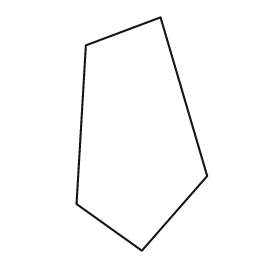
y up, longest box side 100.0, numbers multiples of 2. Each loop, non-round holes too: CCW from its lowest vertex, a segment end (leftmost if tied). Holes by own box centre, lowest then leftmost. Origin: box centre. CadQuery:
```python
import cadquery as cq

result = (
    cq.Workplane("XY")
    .moveTo(0.0, -50.0)
    .lineTo(28.0, -18.0)
    .lineTo(8.0, 50.0)
    .lineTo(-24.0, 38.0)
    .lineTo(-28.0, -30.0)
    .close()
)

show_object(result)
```